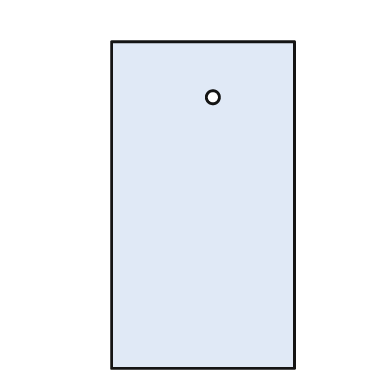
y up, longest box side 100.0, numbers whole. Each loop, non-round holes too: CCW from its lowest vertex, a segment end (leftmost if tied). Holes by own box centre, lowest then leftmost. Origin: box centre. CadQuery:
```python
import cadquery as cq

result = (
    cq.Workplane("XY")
    .moveTo(-28.0, -50.0)
    .lineTo(28.0, -50.0)
    .lineTo(28.0, 50.0)
    .lineTo(-28.0, 50.0)
    .close()
    .moveTo(3.0, 33.0)
    .circle(2.0)
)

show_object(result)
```